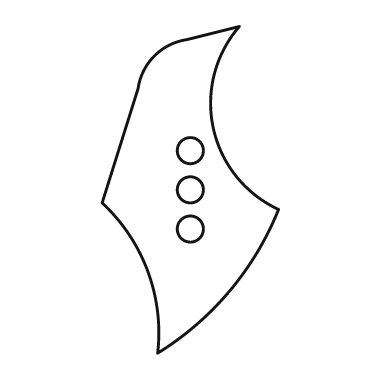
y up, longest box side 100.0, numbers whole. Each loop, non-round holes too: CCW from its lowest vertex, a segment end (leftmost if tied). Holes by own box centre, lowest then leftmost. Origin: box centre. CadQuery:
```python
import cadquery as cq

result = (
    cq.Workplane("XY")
    .moveTo(-10.0, -50.0)
    .threePointArc((12.0, -31.0), (27.0, -6.0))
    .threePointArc((7.0, 19.0), (15.0, 50.0))
    .lineTo(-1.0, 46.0)
    .threePointArc((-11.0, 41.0), (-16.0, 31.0))
    .lineTo(-27.0, -4.0)
    .threePointArc((-13.0, -25.0), (-10.0, -50.0))
    .close()
    .moveTo(0.0, -12.0)
    .circle(4.0)
    .moveTo(0.0, 0.0)
    .circle(4.0)
    .moveTo(0.0, 12.0)
    .circle(4.0)
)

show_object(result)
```